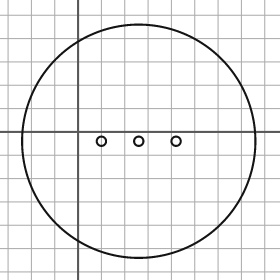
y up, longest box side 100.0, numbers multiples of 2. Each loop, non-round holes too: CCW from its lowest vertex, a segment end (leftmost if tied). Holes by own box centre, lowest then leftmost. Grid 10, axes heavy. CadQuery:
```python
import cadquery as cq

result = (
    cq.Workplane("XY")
    .moveTo(26.0, -4.0)
    .circle(50.0)
    .moveTo(10.0, -4.0)
    .circle(2.0)
    .moveTo(26.0, -4.0)
    .circle(2.0)
    .moveTo(42.0, -4.0)
    .circle(2.0)
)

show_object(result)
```